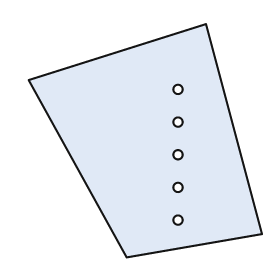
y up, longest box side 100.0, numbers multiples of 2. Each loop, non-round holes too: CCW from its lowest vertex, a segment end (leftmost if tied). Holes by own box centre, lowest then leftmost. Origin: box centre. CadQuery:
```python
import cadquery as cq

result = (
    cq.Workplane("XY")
    .moveTo(-8.0, -50.0)
    .lineTo(50.0, -40.0)
    .lineTo(26.0, 50.0)
    .lineTo(-50.0, 26.0)
    .close()
    .moveTo(14.0, -34.0)
    .circle(2.0)
    .moveTo(14.0, -20.0)
    .circle(2.0)
    .moveTo(14.0, -6.0)
    .circle(2.0)
    .moveTo(14.0, 8.0)
    .circle(2.0)
    .moveTo(14.0, 22.0)
    .circle(2.0)
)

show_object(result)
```